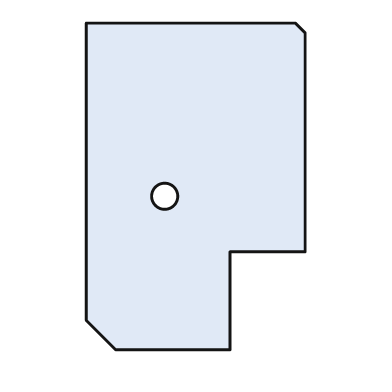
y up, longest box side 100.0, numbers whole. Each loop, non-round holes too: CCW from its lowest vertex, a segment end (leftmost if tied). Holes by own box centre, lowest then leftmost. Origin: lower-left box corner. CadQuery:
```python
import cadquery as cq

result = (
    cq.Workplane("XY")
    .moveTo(9.0, 0.0)
    .lineTo(44.0, 0.0)
    .lineTo(44.0, 30.0)
    .lineTo(67.0, 30.0)
    .lineTo(67.0, 97.0)
    .lineTo(64.0, 100.0)
    .lineTo(0.0, 100.0)
    .lineTo(0.0, 9.0)
    .close()
    .moveTo(24.0, 47.0)
    .circle(4.0)
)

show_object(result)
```